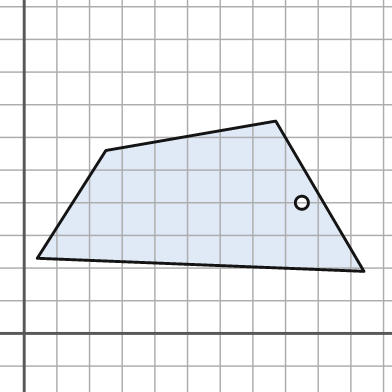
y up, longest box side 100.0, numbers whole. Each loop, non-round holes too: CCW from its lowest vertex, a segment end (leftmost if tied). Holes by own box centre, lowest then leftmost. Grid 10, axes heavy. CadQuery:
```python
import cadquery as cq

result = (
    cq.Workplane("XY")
    .moveTo(104.0, 19.0)
    .lineTo(77.0, 65.0)
    .lineTo(25.0, 56.0)
    .lineTo(4.0, 23.0)
    .close()
    .moveTo(85.0, 40.0)
    .circle(2.0)
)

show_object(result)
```